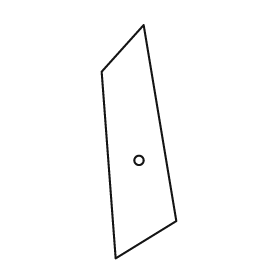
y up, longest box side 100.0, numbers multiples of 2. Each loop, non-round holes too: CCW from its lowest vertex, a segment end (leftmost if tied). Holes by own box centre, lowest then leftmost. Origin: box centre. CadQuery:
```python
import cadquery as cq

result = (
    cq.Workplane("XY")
    .moveTo(-10.0, -50.0)
    .lineTo(16.0, -34.0)
    .lineTo(2.0, 50.0)
    .lineTo(-16.0, 30.0)
    .close()
    .moveTo(0.0, -8.0)
    .circle(2.0)
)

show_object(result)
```